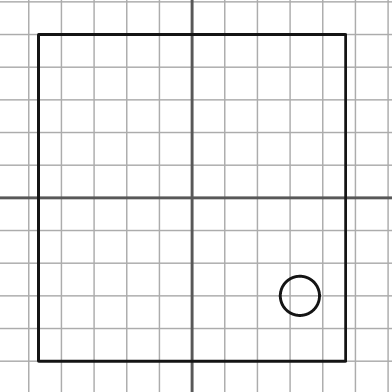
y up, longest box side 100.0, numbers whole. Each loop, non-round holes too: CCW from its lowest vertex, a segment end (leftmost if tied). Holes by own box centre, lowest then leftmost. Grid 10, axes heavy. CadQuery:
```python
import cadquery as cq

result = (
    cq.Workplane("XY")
    .moveTo(-47.0, -50.0)
    .lineTo(47.0, -50.0)
    .lineTo(47.0, 50.0)
    .lineTo(-47.0, 50.0)
    .close()
    .moveTo(33.0, -30.0)
    .circle(6.0)
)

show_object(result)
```